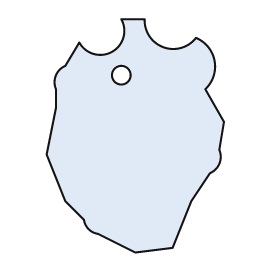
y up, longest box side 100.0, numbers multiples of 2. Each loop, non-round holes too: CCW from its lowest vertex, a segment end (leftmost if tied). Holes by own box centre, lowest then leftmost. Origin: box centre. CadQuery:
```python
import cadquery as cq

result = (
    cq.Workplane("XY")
    .moveTo(0.0, -50.0)
    .lineTo(16.0, -48.0)
    .lineTo(24.0, -28.0)
    .lineTo(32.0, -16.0)
    .threePointArc((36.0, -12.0), (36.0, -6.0))
    .lineTo(38.0, 6.0)
    .lineTo(30.0, 20.0)
    .threePointArc((34.0, 32.0), (26.0, 42.0))
    .threePointArc((12.0, 38.0), (4.0, 50.0))
    .lineTo(-6.0, 50.0)
    .threePointArc((-10.0, 36.0), (-24.0, 40.0))
    .lineTo(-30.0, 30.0)
    .threePointArc((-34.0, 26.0), (-34.0, 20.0))
    .lineTo(-34.0, 12.0)
    .lineTo(-38.0, -8.0)
    .lineTo(-30.0, -28.0)
    .lineTo(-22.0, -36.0)
    .threePointArc((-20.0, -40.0), (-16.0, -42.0))
    .close()
    .moveTo(-6.0, 26.0)
    .circle(4.0)
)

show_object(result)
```